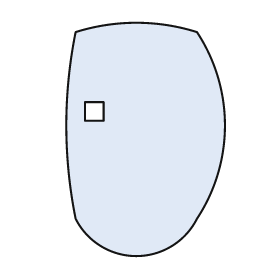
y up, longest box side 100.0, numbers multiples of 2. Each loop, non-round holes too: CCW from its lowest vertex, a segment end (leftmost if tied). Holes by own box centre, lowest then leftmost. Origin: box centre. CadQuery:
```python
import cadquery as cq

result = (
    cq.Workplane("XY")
    .moveTo(-30.0, -34.0)
    .threePointArc((-4.0, -50.0), (22.0, -34.0))
    .threePointArc((34.0, 6.0), (22.0, 46.0))
    .threePointArc((-4.0, 50.0), (-30.0, 46.0))
    .threePointArc((-34.0, 6.0), (-30.0, -34.0))
    .close()
    .moveTo(-26.0, 8.0)
    .lineTo(-18.0, 8.0)
    .lineTo(-18.0, 16.0)
    .lineTo(-26.0, 16.0)
    .close()
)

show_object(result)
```